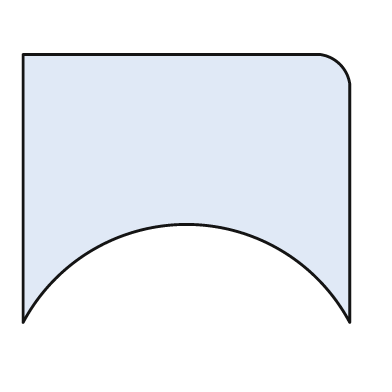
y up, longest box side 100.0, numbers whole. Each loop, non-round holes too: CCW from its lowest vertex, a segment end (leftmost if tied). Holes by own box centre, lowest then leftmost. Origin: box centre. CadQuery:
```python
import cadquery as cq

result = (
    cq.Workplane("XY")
    .moveTo(-50.0, -41.0)
    .threePointArc((0.0, -11.0), (50.0, -41.0))
    .lineTo(50.0, 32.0)
    .threePointArc((47.0, 38.0), (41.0, 41.0))
    .lineTo(-50.0, 41.0)
    .close()
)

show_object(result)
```